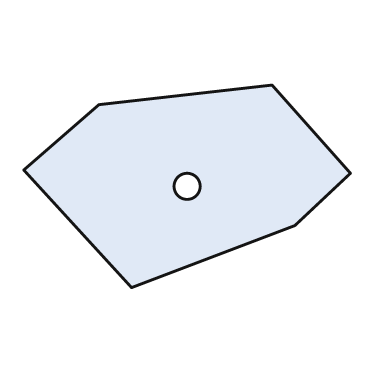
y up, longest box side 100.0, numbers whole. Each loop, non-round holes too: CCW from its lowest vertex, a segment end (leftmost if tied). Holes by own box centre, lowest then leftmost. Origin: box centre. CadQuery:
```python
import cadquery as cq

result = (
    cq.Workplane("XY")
    .moveTo(-17.0, -31.0)
    .lineTo(33.0, -12.0)
    .lineTo(50.0, 4.0)
    .lineTo(26.0, 31.0)
    .lineTo(-27.0, 25.0)
    .lineTo(-50.0, 5.0)
    .close()
    .moveTo(0.0, 0.0)
    .circle(4.0)
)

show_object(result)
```